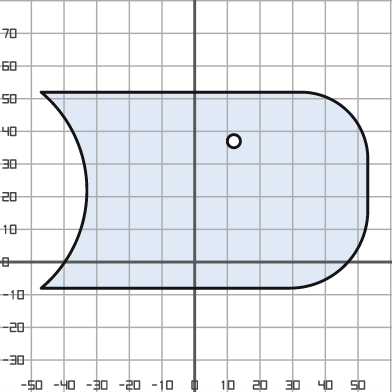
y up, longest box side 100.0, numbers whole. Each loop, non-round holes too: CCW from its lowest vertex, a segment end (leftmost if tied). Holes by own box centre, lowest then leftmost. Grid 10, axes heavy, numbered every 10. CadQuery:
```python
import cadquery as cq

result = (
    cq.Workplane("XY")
    .moveTo(-47.0, -8.0)
    .lineTo(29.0, -8.0)
    .threePointArc((46.0, -1.0), (53.0, 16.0))
    .lineTo(53.0, 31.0)
    .threePointArc((47.0, 46.0), (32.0, 52.0))
    .lineTo(-47.0, 52.0)
    .threePointArc((-33.0, 22.0), (-47.0, -8.0))
    .close()
    .moveTo(12.0, 37.0)
    .circle(2.0)
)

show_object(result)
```